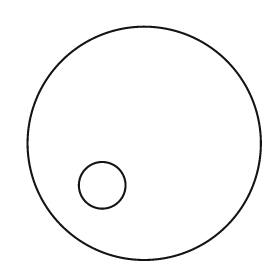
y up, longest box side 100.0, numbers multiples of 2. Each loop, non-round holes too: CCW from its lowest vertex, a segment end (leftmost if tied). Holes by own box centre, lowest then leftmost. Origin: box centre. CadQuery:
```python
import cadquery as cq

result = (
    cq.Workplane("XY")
    .moveTo(0.0, 0.0)
    .circle(50.0)
    .moveTo(-18.0, -18.0)
    .circle(10.0)
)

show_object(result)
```